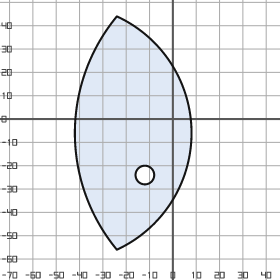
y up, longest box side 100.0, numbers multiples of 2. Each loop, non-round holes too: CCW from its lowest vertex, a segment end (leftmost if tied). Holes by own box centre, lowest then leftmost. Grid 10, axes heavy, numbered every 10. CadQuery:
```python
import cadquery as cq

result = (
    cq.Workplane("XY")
    .moveTo(-24.0, -56.0)
    .threePointArc((8.0, -6.0), (-24.0, 44.0))
    .threePointArc((-42.0, -6.0), (-24.0, -56.0))
    .close()
    .moveTo(-12.0, -24.0)
    .circle(4.0)
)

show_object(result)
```